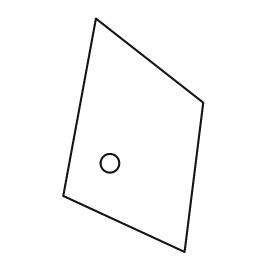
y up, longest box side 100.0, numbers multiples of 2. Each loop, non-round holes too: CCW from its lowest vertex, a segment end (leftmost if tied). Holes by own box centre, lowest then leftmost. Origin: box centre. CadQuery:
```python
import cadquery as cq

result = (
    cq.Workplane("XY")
    .moveTo(22.0, -50.0)
    .lineTo(30.0, 14.0)
    .lineTo(-16.0, 50.0)
    .lineTo(-30.0, -26.0)
    .close()
    .moveTo(-10.0, -12.0)
    .circle(4.0)
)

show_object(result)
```